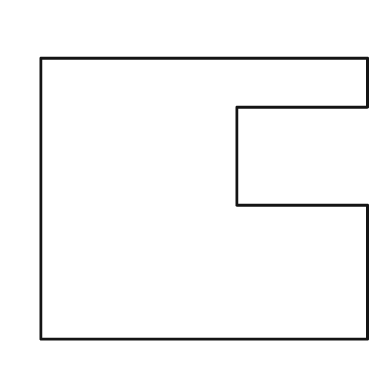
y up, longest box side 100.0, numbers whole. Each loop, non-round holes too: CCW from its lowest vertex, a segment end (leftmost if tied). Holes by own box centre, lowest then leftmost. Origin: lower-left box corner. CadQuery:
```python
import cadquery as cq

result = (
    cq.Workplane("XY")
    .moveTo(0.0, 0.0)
    .lineTo(100.0, 0.0)
    .lineTo(100.0, 41.0)
    .lineTo(60.0, 41.0)
    .lineTo(60.0, 71.0)
    .lineTo(100.0, 71.0)
    .lineTo(100.0, 86.0)
    .lineTo(0.0, 86.0)
    .close()
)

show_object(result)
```